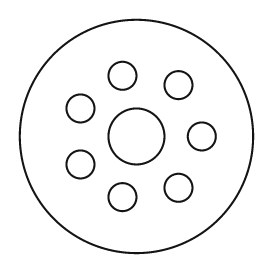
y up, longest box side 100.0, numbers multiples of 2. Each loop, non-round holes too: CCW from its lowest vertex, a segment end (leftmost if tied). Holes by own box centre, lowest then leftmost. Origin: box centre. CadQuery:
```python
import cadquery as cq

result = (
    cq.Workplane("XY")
    .moveTo(0.0, 0.0)
    .circle(50.0)
    .moveTo(-6.0, -26.0)
    .circle(6.0)
    .moveTo(18.0, -22.0)
    .circle(6.0)
    .moveTo(-24.0, -12.0)
    .circle(6.0)
    .moveTo(0.0, 0.0)
    .circle(12.0)
    .moveTo(28.0, 0.0)
    .circle(6.0)
    .moveTo(-24.0, 12.0)
    .circle(6.0)
    .moveTo(18.0, 22.0)
    .circle(6.0)
    .moveTo(-6.0, 26.0)
    .circle(6.0)
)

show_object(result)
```